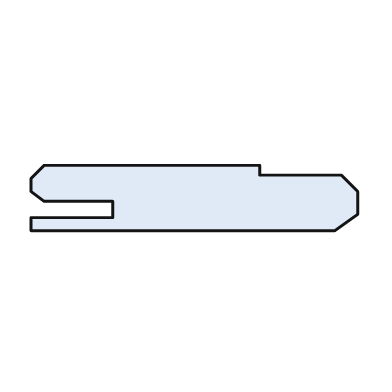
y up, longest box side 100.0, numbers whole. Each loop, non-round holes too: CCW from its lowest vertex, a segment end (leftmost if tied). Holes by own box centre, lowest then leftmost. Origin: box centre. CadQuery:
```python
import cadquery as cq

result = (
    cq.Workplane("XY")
    .moveTo(-50.0, -10.0)
    .lineTo(43.0, -10.0)
    .lineTo(50.0, -5.0)
    .lineTo(50.0, 2.0)
    .lineTo(45.0, 7.0)
    .lineTo(20.0, 7.0)
    .lineTo(20.0, 10.0)
    .lineTo(-46.0, 10.0)
    .lineTo(-50.0, 6.0)
    .lineTo(-50.0, 2.0)
    .lineTo(-46.0, -1.0)
    .lineTo(-25.0, -1.0)
    .lineTo(-25.0, -6.0)
    .lineTo(-50.0, -6.0)
    .close()
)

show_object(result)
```